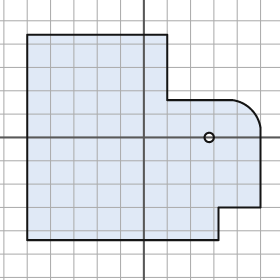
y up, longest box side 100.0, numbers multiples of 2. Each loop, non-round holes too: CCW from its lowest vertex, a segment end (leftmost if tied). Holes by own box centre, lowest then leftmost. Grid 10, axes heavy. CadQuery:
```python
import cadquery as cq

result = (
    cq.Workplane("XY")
    .moveTo(-50.0, -44.0)
    .lineTo(32.0, -44.0)
    .lineTo(32.0, -30.0)
    .lineTo(50.0, -30.0)
    .lineTo(50.0, 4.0)
    .threePointArc((46.0, 12.0), (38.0, 16.0))
    .lineTo(10.0, 16.0)
    .lineTo(10.0, 44.0)
    .lineTo(-50.0, 44.0)
    .close()
    .moveTo(28.0, 0.0)
    .circle(2.0)
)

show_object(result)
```